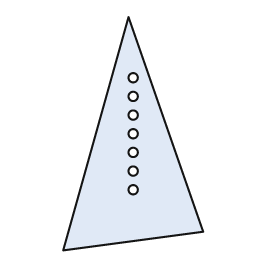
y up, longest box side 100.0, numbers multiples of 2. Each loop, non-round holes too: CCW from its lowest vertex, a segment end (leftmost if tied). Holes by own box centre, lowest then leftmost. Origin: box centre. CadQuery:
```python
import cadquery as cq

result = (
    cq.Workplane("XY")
    .moveTo(-30.0, -50.0)
    .lineTo(30.0, -42.0)
    .lineTo(-2.0, 50.0)
    .close()
    .moveTo(0.0, -24.0)
    .circle(2.0)
    .moveTo(0.0, -16.0)
    .circle(2.0)
    .moveTo(0.0, -8.0)
    .circle(2.0)
    .moveTo(0.0, 0.0)
    .circle(2.0)
    .moveTo(0.0, 8.0)
    .circle(2.0)
    .moveTo(0.0, 16.0)
    .circle(2.0)
    .moveTo(0.0, 24.0)
    .circle(2.0)
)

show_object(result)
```